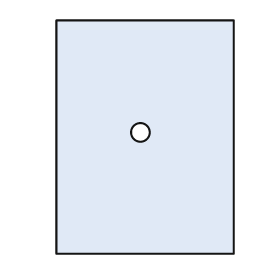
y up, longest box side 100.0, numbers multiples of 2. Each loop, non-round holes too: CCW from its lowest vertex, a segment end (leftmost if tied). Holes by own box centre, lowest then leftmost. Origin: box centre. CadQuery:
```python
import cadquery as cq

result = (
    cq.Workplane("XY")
    .moveTo(-38.0, -50.0)
    .lineTo(38.0, -50.0)
    .lineTo(38.0, 50.0)
    .lineTo(-38.0, 50.0)
    .close()
    .moveTo(-2.0, 2.0)
    .circle(4.0)
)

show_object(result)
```